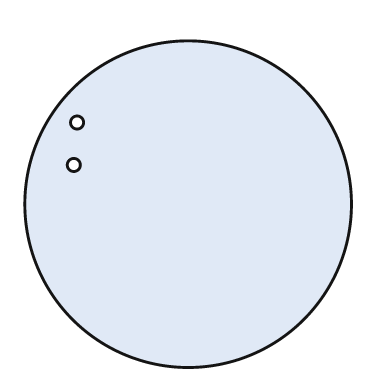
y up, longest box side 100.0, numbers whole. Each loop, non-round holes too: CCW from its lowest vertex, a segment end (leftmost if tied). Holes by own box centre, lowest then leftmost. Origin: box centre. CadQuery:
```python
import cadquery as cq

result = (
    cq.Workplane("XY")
    .moveTo(0.0, 0.0)
    .circle(50.0)
    .moveTo(-35.0, 12.0)
    .circle(2.0)
    .moveTo(-34.0, 25.0)
    .circle(2.0)
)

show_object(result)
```